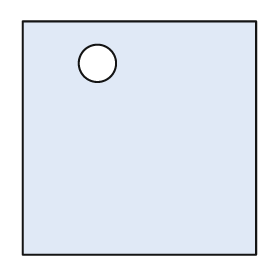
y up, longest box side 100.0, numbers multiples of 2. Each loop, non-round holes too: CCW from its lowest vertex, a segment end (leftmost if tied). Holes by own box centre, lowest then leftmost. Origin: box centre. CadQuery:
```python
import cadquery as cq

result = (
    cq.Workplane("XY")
    .moveTo(-50.0, -50.0)
    .lineTo(50.0, -50.0)
    .lineTo(50.0, 50.0)
    .lineTo(-50.0, 50.0)
    .close()
    .moveTo(-18.0, 32.0)
    .circle(8.0)
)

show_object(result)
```